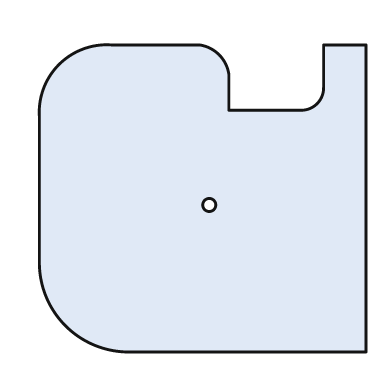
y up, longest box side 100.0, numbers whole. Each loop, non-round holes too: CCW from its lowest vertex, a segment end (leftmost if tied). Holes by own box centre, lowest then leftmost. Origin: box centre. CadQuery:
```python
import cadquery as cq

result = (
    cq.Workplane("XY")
    .moveTo(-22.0, -47.0)
    .lineTo(50.0, -47.0)
    .lineTo(50.0, 47.0)
    .lineTo(37.0, 47.0)
    .lineTo(37.0, 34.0)
    .threePointArc((35.0, 29.0), (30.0, 27.0))
    .lineTo(8.0, 27.0)
    .lineTo(8.0, 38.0)
    .threePointArc((5.0, 44.0), (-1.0, 47.0))
    .lineTo(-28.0, 47.0)
    .threePointArc((-44.0, 41.0), (-50.0, 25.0))
    .lineTo(-50.0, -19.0)
    .threePointArc((-42.0, -39.0), (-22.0, -47.0))
    .close()
    .moveTo(2.0, -2.0)
    .circle(2.0)
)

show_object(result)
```